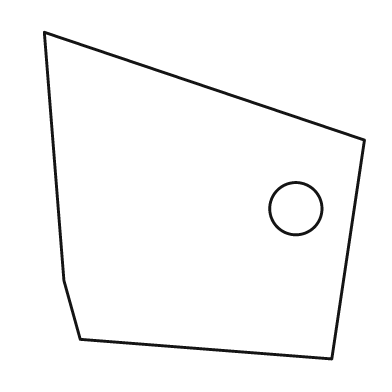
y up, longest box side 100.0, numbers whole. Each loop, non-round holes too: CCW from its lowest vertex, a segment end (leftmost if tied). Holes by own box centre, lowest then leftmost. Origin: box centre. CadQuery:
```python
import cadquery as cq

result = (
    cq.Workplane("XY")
    .moveTo(39.0, -50.0)
    .lineTo(49.0, 17.0)
    .lineTo(-49.0, 50.0)
    .lineTo(-43.0, -26.0)
    .lineTo(-38.0, -44.0)
    .close()
    .moveTo(28.0, -4.0)
    .circle(8.0)
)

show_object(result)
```